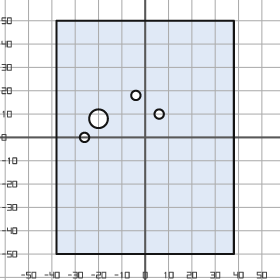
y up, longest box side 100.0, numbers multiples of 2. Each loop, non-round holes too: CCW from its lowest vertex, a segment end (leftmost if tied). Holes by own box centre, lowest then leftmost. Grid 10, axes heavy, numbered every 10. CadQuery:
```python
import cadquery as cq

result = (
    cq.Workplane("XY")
    .moveTo(-38.0, -50.0)
    .lineTo(38.0, -50.0)
    .lineTo(38.0, 50.0)
    .lineTo(-38.0, 50.0)
    .close()
    .moveTo(-26.0, 0.0)
    .circle(2.0)
    .moveTo(-20.0, 8.0)
    .circle(4.0)
    .moveTo(6.0, 10.0)
    .circle(2.0)
    .moveTo(-4.0, 18.0)
    .circle(2.0)
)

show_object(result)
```